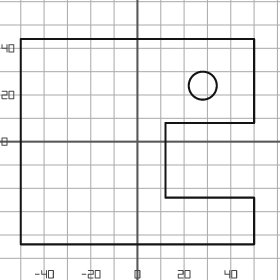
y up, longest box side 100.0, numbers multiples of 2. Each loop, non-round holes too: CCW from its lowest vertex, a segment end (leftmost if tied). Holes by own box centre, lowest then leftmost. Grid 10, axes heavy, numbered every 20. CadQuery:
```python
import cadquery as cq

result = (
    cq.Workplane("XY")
    .moveTo(-50.0, -44.0)
    .lineTo(50.0, -44.0)
    .lineTo(50.0, -24.0)
    .lineTo(12.0, -24.0)
    .lineTo(12.0, 8.0)
    .lineTo(50.0, 8.0)
    .lineTo(50.0, 44.0)
    .lineTo(-50.0, 44.0)
    .close()
    .moveTo(28.0, 24.0)
    .circle(6.0)
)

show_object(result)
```